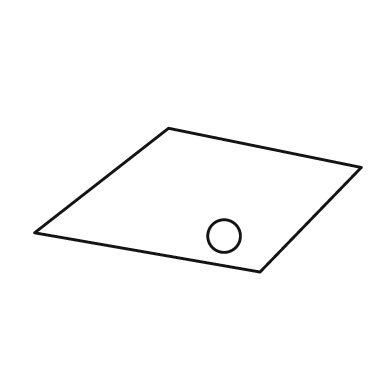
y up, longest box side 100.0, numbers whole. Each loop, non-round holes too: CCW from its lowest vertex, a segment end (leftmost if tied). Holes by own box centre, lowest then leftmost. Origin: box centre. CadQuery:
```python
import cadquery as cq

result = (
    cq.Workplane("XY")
    .moveTo(19.0, -22.0)
    .lineTo(50.0, 10.0)
    .lineTo(-9.0, 22.0)
    .lineTo(-50.0, -10.0)
    .close()
    .moveTo(8.0, -11.0)
    .circle(5.0)
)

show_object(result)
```